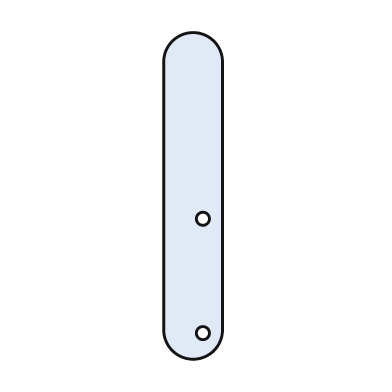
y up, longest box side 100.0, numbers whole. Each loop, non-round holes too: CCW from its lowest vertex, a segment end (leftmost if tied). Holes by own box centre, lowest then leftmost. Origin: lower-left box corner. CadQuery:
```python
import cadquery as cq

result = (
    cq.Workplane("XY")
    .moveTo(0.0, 9.0)
    .threePointArc((9.0, 0.0), (18.0, 9.0))
    .lineTo(18.0, 91.0)
    .threePointArc((9.0, 100.0), (0.0, 91.0))
    .close()
    .moveTo(12.0, 8.0)
    .circle(2.0)
    .moveTo(12.0, 43.0)
    .circle(2.0)
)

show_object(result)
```